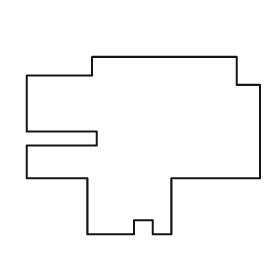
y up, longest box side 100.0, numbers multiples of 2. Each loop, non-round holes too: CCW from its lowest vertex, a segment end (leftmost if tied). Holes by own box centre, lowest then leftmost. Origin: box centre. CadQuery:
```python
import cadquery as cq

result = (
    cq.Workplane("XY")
    .moveTo(-24.0, -38.0)
    .lineTo(-4.0, -38.0)
    .lineTo(-4.0, -32.0)
    .lineTo(4.0, -32.0)
    .lineTo(4.0, -38.0)
    .lineTo(12.0, -38.0)
    .lineTo(12.0, -14.0)
    .lineTo(50.0, -14.0)
    .lineTo(50.0, 26.0)
    .lineTo(40.0, 26.0)
    .lineTo(40.0, 38.0)
    .lineTo(-22.0, 38.0)
    .lineTo(-22.0, 30.0)
    .lineTo(-50.0, 30.0)
    .lineTo(-50.0, 6.0)
    .lineTo(-20.0, 6.0)
    .lineTo(-20.0, 0.0)
    .lineTo(-50.0, 0.0)
    .lineTo(-50.0, -14.0)
    .lineTo(-24.0, -14.0)
    .close()
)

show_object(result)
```